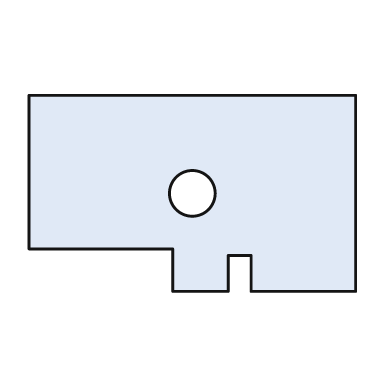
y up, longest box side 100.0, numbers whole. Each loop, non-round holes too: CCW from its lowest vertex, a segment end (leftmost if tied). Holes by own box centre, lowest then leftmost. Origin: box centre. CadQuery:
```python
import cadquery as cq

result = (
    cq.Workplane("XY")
    .moveTo(-6.0, -30.0)
    .lineTo(11.0, -30.0)
    .lineTo(11.0, -19.0)
    .lineTo(18.0, -19.0)
    .lineTo(18.0, -30.0)
    .lineTo(50.0, -30.0)
    .lineTo(50.0, 30.0)
    .lineTo(-50.0, 30.0)
    .lineTo(-50.0, -17.0)
    .lineTo(-6.0, -17.0)
    .close()
    .moveTo(0.0, 0.0)
    .circle(7.0)
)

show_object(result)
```